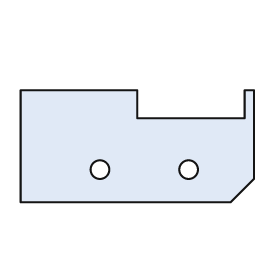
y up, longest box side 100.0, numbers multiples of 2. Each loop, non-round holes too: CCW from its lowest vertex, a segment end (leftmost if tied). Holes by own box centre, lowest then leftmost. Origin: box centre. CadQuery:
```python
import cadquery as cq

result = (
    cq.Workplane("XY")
    .moveTo(-50.0, -24.0)
    .lineTo(40.0, -24.0)
    .lineTo(50.0, -14.0)
    .lineTo(50.0, 24.0)
    .lineTo(46.0, 24.0)
    .lineTo(46.0, 12.0)
    .lineTo(0.0, 12.0)
    .lineTo(0.0, 24.0)
    .lineTo(-50.0, 24.0)
    .close()
    .moveTo(-16.0, -10.0)
    .circle(4.0)
    .moveTo(22.0, -10.0)
    .circle(4.0)
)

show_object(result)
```